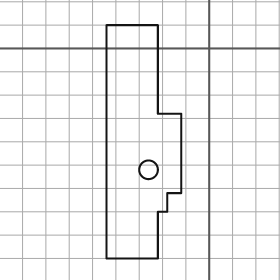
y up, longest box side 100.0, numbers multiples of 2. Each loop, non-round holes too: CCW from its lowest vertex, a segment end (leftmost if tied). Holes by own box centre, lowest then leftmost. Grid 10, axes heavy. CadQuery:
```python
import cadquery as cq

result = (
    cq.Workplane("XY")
    .moveTo(-44.0, -90.0)
    .lineTo(-22.0, -90.0)
    .lineTo(-22.0, -70.0)
    .lineTo(-18.0, -70.0)
    .lineTo(-18.0, -62.0)
    .lineTo(-12.0, -62.0)
    .lineTo(-12.0, -28.0)
    .lineTo(-22.0, -28.0)
    .lineTo(-22.0, 10.0)
    .lineTo(-44.0, 10.0)
    .close()
    .moveTo(-26.0, -52.0)
    .circle(4.0)
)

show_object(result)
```